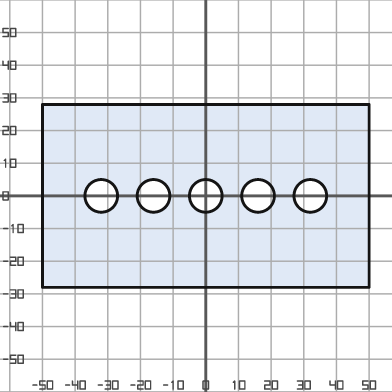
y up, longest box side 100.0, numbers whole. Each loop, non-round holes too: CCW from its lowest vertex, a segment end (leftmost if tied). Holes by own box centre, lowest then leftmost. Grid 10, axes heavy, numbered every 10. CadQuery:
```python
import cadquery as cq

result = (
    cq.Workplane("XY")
    .moveTo(-50.0, -28.0)
    .lineTo(50.0, -28.0)
    .lineTo(50.0, 28.0)
    .lineTo(-50.0, 28.0)
    .close()
    .moveTo(-32.0, 0.0)
    .circle(5.0)
    .moveTo(-16.0, 0.0)
    .circle(5.0)
    .moveTo(0.0, 0.0)
    .circle(5.0)
    .moveTo(16.0, 0.0)
    .circle(5.0)
    .moveTo(32.0, 0.0)
    .circle(5.0)
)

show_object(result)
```